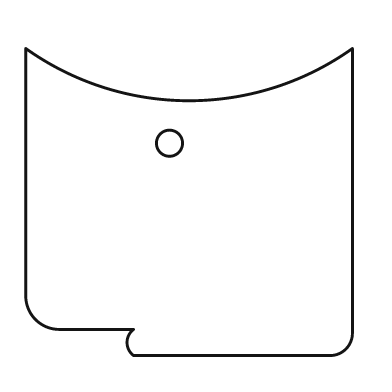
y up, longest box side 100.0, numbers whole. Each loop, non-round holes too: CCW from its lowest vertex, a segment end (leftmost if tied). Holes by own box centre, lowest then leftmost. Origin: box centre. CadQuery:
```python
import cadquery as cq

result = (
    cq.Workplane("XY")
    .moveTo(-17.0, -47.0)
    .lineTo(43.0, -47.0)
    .threePointArc((48.0, -45.0), (50.0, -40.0))
    .lineTo(50.0, 47.0)
    .threePointArc((0.0, 31.0), (-50.0, 47.0))
    .lineTo(-50.0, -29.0)
    .threePointArc((-47.0, -36.0), (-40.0, -39.0))
    .lineTo(-17.0, -39.0)
    .threePointArc((-19.0, -43.0), (-17.0, -47.0))
    .close()
    .moveTo(-6.0, 18.0)
    .circle(4.0)
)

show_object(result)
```